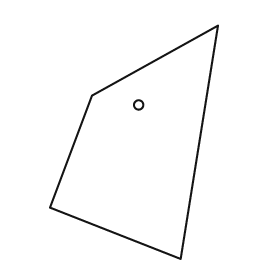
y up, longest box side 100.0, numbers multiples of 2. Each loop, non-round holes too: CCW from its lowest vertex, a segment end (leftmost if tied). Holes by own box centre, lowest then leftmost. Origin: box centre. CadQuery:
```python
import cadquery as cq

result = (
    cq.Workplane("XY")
    .moveTo(20.0, -50.0)
    .lineTo(36.0, 50.0)
    .lineTo(-18.0, 20.0)
    .lineTo(-36.0, -28.0)
    .close()
    .moveTo(2.0, 16.0)
    .circle(2.0)
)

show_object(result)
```